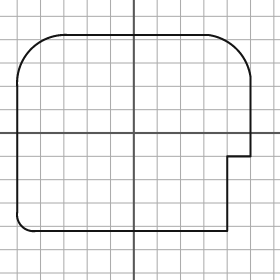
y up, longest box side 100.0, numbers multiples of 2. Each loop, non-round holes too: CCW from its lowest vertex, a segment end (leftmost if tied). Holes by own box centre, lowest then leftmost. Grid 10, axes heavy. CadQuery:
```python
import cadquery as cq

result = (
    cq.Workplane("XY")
    .moveTo(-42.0, -42.0)
    .lineTo(40.0, -42.0)
    .lineTo(40.0, -10.0)
    .lineTo(50.0, -10.0)
    .lineTo(50.0, 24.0)
    .threePointArc((44.0, 36.0), (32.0, 42.0))
    .lineTo(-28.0, 42.0)
    .threePointArc((-44.0, 36.0), (-50.0, 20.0))
    .lineTo(-50.0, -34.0)
    .threePointArc((-48.0, -40.0), (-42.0, -42.0))
    .close()
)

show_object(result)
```